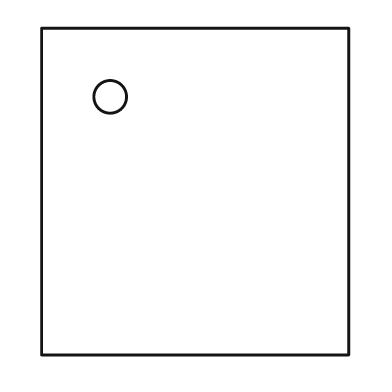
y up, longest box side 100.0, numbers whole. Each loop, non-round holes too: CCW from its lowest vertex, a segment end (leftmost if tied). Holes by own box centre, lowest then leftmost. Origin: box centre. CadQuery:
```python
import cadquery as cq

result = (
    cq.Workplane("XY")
    .moveTo(-47.0, -50.0)
    .lineTo(47.0, -50.0)
    .lineTo(47.0, 50.0)
    .lineTo(-47.0, 50.0)
    .close()
    .moveTo(-26.0, 29.0)
    .circle(5.0)
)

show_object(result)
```